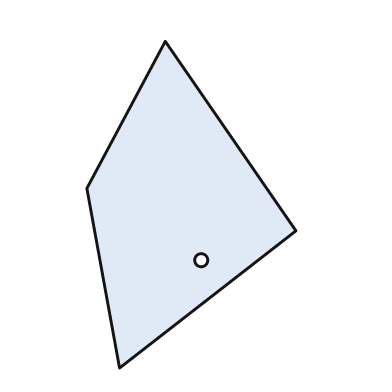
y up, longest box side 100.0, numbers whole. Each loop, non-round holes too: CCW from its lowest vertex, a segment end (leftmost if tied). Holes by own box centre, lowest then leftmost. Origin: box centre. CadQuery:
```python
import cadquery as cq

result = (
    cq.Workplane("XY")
    .moveTo(-22.0, -50.0)
    .lineTo(32.0, -8.0)
    .lineTo(-8.0, 50.0)
    .lineTo(-32.0, 5.0)
    .close()
    .moveTo(3.0, -17.0)
    .circle(2.0)
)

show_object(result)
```